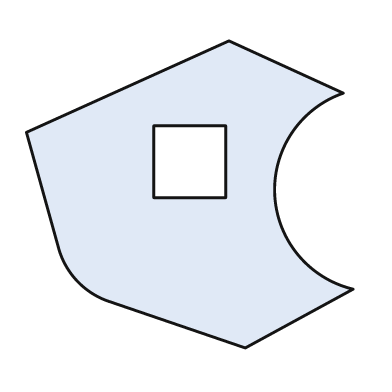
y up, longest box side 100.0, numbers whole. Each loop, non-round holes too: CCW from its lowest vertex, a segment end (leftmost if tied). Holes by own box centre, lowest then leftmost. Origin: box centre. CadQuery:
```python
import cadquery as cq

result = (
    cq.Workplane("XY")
    .moveTo(17.0, -47.0)
    .lineTo(50.0, -29.0)
    .threePointArc((26.0, 0.0), (47.0, 31.0))
    .lineTo(12.0, 47.0)
    .lineTo(-50.0, 19.0)
    .lineTo(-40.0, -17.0)
    .threePointArc((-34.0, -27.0), (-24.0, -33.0))
    .close()
    .moveTo(-11.0, -1.0)
    .lineTo(11.0, -1.0)
    .lineTo(11.0, 21.0)
    .lineTo(-11.0, 21.0)
    .close()
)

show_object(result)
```